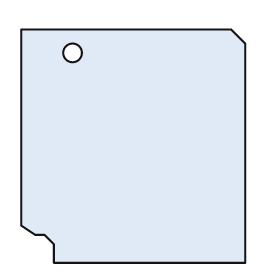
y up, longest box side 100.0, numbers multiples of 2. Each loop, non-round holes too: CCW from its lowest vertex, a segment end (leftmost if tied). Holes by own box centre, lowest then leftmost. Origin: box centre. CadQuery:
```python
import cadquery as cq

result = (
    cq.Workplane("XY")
    .moveTo(-34.0, -50.0)
    .lineTo(48.0, -50.0)
    .lineTo(48.0, 44.0)
    .lineTo(42.0, 50.0)
    .lineTo(-48.0, 50.0)
    .lineTo(-48.0, -34.0)
    .lineTo(-42.0, -38.0)
    .lineTo(-38.0, -38.0)
    .lineTo(-34.0, -42.0)
    .close()
    .moveTo(-26.0, 40.0)
    .circle(4.0)
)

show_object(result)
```